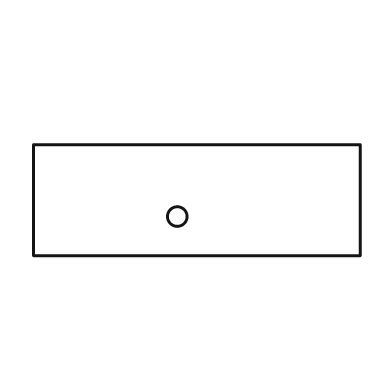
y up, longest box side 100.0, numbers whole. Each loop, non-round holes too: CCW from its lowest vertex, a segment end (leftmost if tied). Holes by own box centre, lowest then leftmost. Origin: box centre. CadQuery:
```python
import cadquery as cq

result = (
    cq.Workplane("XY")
    .moveTo(-50.0, -17.0)
    .lineTo(50.0, -17.0)
    .lineTo(50.0, 17.0)
    .lineTo(-50.0, 17.0)
    .close()
    .moveTo(-6.0, -5.0)
    .circle(3.0)
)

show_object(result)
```